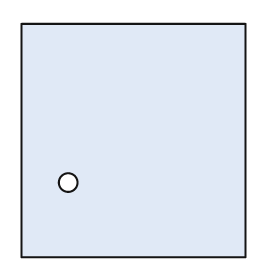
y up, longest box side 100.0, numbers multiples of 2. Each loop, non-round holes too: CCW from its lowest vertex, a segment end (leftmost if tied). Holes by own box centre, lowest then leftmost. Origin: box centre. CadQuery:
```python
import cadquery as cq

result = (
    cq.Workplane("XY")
    .moveTo(-48.0, -50.0)
    .lineTo(48.0, -50.0)
    .lineTo(48.0, 50.0)
    .lineTo(-48.0, 50.0)
    .close()
    .moveTo(-28.0, -18.0)
    .circle(4.0)
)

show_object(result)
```